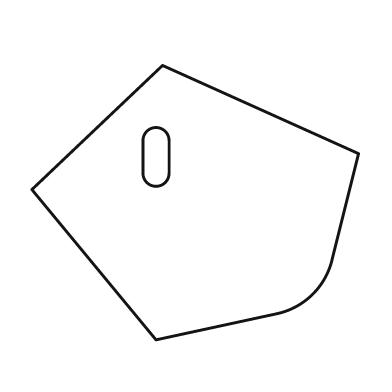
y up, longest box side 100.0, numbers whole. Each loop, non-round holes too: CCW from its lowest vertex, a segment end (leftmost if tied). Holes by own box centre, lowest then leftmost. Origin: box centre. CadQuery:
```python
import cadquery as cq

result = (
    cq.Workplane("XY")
    .moveTo(-12.0, -42.0)
    .lineTo(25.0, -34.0)
    .threePointArc((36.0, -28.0), (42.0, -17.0))
    .lineTo(50.0, 15.0)
    .lineTo(-10.0, 42.0)
    .lineTo(-50.0, 4.0)
    .close()
    .moveTo(-16.0, 9.0)
    .threePointArc((-12.0, 5.0), (-8.0, 9.0))
    .lineTo(-8.0, 19.0)
    .threePointArc((-12.0, 23.0), (-16.0, 19.0))
    .close()
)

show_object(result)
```